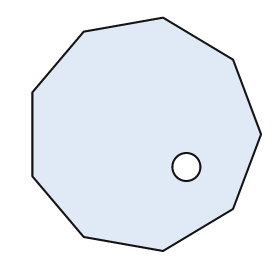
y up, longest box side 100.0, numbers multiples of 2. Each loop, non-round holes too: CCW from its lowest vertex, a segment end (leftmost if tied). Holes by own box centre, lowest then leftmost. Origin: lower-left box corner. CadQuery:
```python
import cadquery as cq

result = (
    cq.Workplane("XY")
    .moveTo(56.0, 0.0)
    .lineTo(86.0, 18.0)
    .lineTo(98.0, 50.0)
    .lineTo(86.0, 82.0)
    .lineTo(56.0, 100.0)
    .lineTo(22.0, 94.0)
    .lineTo(0.0, 68.0)
    .lineTo(0.0, 32.0)
    .lineTo(22.0, 6.0)
    .close()
    .moveTo(66.0, 36.0)
    .circle(6.0)
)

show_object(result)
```